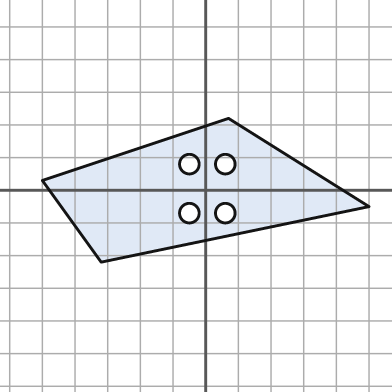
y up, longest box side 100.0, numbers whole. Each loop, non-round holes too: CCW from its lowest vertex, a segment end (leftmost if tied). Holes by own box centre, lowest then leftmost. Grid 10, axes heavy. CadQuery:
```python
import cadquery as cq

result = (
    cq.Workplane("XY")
    .moveTo(-32.0, -22.0)
    .lineTo(50.0, -5.0)
    .lineTo(7.0, 22.0)
    .lineTo(-50.0, 3.0)
    .close()
    .moveTo(-5.0, -7.0)
    .circle(3.0)
    .moveTo(6.0, -7.0)
    .circle(3.0)
    .moveTo(-5.0, 8.0)
    .circle(3.0)
    .moveTo(6.0, 8.0)
    .circle(3.0)
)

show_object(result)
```